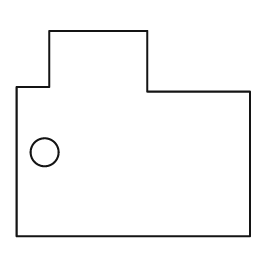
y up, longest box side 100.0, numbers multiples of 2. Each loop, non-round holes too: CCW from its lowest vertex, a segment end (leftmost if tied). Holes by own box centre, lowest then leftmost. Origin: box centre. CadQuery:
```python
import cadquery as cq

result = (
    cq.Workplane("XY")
    .moveTo(-50.0, -44.0)
    .lineTo(50.0, -44.0)
    .lineTo(50.0, 18.0)
    .lineTo(6.0, 18.0)
    .lineTo(6.0, 44.0)
    .lineTo(-36.0, 44.0)
    .lineTo(-36.0, 20.0)
    .lineTo(-50.0, 20.0)
    .close()
    .moveTo(-38.0, -8.0)
    .circle(6.0)
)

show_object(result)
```